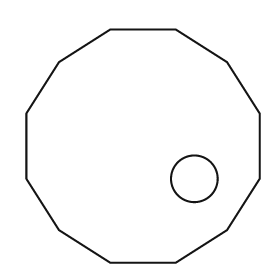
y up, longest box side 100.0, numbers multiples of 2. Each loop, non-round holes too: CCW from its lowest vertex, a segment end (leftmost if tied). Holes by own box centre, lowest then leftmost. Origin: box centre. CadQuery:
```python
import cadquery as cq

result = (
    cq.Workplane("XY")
    .moveTo(-14.0, -50.0)
    .lineTo(14.0, -50.0)
    .lineTo(36.0, -36.0)
    .lineTo(50.0, -14.0)
    .lineTo(50.0, 14.0)
    .lineTo(36.0, 36.0)
    .lineTo(14.0, 50.0)
    .lineTo(-14.0, 50.0)
    .lineTo(-36.0, 36.0)
    .lineTo(-50.0, 14.0)
    .lineTo(-50.0, -14.0)
    .lineTo(-36.0, -36.0)
    .close()
    .moveTo(22.0, -14.0)
    .circle(10.0)
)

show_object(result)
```